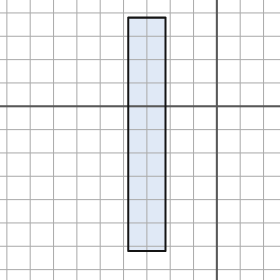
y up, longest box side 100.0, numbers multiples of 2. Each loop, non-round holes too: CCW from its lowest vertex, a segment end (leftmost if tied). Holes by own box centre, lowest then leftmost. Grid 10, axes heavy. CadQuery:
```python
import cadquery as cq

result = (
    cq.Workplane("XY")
    .moveTo(-38.0, -62.0)
    .lineTo(-22.0, -62.0)
    .lineTo(-22.0, 38.0)
    .lineTo(-38.0, 38.0)
    .close()
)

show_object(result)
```